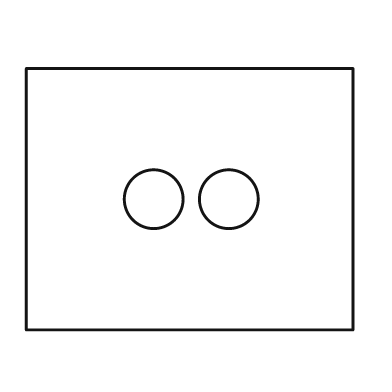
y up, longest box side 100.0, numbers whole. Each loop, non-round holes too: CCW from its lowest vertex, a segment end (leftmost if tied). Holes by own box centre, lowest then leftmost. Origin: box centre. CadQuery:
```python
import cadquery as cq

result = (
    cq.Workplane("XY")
    .moveTo(-50.0, -40.0)
    .lineTo(50.0, -40.0)
    .lineTo(50.0, 40.0)
    .lineTo(-50.0, 40.0)
    .close()
    .moveTo(-11.0, 0.0)
    .circle(9.0)
    .moveTo(12.0, 0.0)
    .circle(9.0)
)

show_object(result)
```